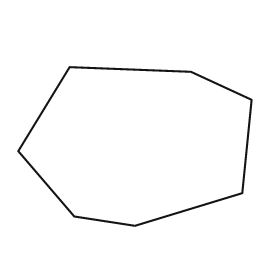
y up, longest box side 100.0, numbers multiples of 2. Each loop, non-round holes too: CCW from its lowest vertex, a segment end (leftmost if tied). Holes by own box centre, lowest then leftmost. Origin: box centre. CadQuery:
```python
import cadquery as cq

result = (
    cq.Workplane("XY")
    .moveTo(0.0, -34.0)
    .lineTo(46.0, -20.0)
    .lineTo(50.0, 20.0)
    .lineTo(24.0, 32.0)
    .lineTo(-28.0, 34.0)
    .lineTo(-50.0, -2.0)
    .lineTo(-26.0, -30.0)
    .close()
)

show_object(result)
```